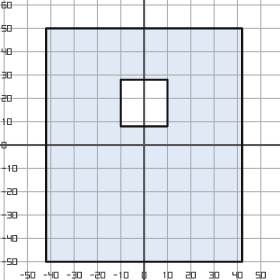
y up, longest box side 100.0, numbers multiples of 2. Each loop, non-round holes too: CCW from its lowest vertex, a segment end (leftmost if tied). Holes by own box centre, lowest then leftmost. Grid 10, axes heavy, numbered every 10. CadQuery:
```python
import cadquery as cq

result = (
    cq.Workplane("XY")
    .moveTo(-42.0, -50.0)
    .lineTo(42.0, -50.0)
    .lineTo(42.0, 50.0)
    .lineTo(-42.0, 50.0)
    .close()
    .moveTo(-10.0, 8.0)
    .lineTo(10.0, 8.0)
    .lineTo(10.0, 28.0)
    .lineTo(-10.0, 28.0)
    .close()
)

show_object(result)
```